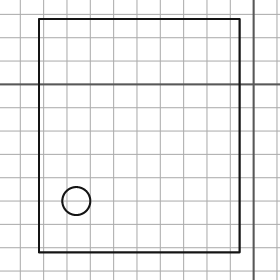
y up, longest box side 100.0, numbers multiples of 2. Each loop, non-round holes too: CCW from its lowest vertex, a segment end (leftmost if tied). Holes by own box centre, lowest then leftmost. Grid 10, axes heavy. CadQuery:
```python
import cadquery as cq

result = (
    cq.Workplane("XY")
    .moveTo(-92.0, -72.0)
    .lineTo(-6.0, -72.0)
    .lineTo(-6.0, 28.0)
    .lineTo(-92.0, 28.0)
    .close()
    .moveTo(-76.0, -50.0)
    .circle(6.0)
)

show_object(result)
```